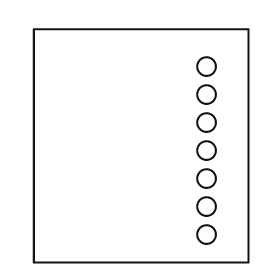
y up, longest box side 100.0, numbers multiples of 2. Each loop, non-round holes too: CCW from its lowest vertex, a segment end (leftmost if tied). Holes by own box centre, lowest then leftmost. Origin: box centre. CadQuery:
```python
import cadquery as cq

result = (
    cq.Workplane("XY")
    .moveTo(-46.0, -50.0)
    .lineTo(46.0, -50.0)
    .lineTo(46.0, 50.0)
    .lineTo(-46.0, 50.0)
    .close()
    .moveTo(28.0, -38.0)
    .circle(4.0)
    .moveTo(28.0, -26.0)
    .circle(4.0)
    .moveTo(28.0, -14.0)
    .circle(4.0)
    .moveTo(28.0, -2.0)
    .circle(4.0)
    .moveTo(28.0, 10.0)
    .circle(4.0)
    .moveTo(28.0, 22.0)
    .circle(4.0)
    .moveTo(28.0, 34.0)
    .circle(4.0)
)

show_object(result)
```